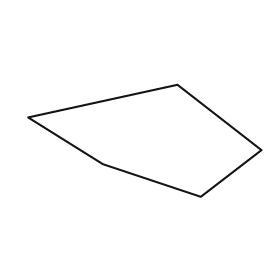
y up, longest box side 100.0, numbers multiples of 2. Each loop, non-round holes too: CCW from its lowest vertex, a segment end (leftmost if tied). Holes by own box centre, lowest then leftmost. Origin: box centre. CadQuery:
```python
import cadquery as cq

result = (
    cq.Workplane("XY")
    .moveTo(24.0, -24.0)
    .lineTo(50.0, -4.0)
    .lineTo(14.0, 24.0)
    .lineTo(-50.0, 10.0)
    .lineTo(-18.0, -10.0)
    .close()
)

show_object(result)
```